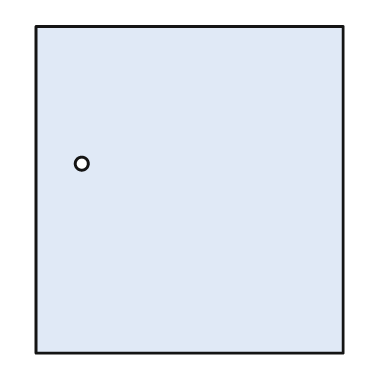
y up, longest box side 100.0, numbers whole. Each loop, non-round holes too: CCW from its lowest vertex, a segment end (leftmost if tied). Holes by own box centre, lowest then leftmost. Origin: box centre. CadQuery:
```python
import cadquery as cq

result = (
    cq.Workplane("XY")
    .moveTo(-47.0, -50.0)
    .lineTo(47.0, -50.0)
    .lineTo(47.0, 50.0)
    .lineTo(-47.0, 50.0)
    .close()
    .moveTo(-33.0, 8.0)
    .circle(2.0)
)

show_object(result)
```